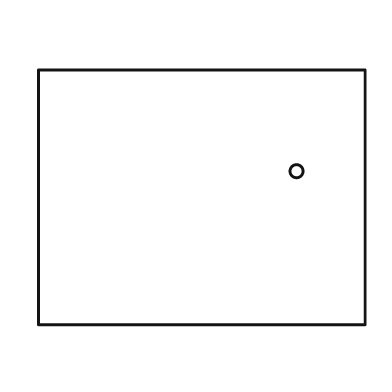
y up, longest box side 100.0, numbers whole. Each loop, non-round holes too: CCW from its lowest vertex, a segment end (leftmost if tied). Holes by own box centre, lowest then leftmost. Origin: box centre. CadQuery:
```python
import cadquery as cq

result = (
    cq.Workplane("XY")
    .moveTo(-50.0, -39.0)
    .lineTo(50.0, -39.0)
    .lineTo(50.0, 39.0)
    .lineTo(-50.0, 39.0)
    .close()
    .moveTo(29.0, 8.0)
    .circle(2.0)
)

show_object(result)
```